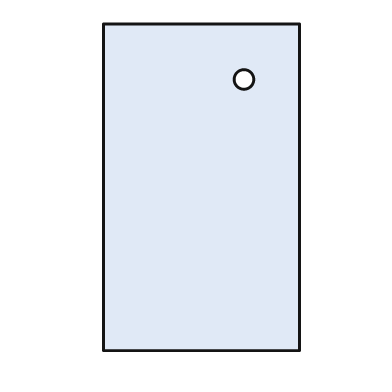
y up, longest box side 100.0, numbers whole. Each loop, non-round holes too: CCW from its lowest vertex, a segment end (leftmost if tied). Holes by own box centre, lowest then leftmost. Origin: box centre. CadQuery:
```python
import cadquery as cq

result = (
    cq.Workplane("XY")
    .moveTo(-30.0, -50.0)
    .lineTo(30.0, -50.0)
    .lineTo(30.0, 50.0)
    .lineTo(-30.0, 50.0)
    .close()
    .moveTo(13.0, 33.0)
    .circle(3.0)
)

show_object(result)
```